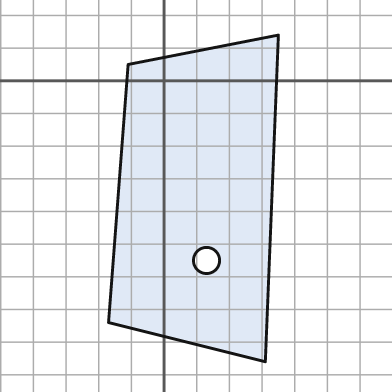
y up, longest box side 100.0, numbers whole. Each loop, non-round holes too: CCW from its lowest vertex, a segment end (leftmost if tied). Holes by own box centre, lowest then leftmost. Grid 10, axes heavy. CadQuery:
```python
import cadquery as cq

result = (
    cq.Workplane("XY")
    .moveTo(31.0, -86.0)
    .lineTo(35.0, 14.0)
    .lineTo(-11.0, 5.0)
    .lineTo(-17.0, -74.0)
    .close()
    .moveTo(13.0, -55.0)
    .circle(4.0)
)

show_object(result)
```